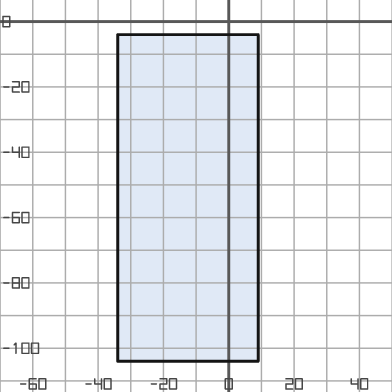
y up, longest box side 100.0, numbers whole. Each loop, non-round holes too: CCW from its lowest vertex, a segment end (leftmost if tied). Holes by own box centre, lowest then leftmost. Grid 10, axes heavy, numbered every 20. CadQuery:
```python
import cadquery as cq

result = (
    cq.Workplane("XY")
    .moveTo(-34.0, -104.0)
    .lineTo(9.0, -104.0)
    .lineTo(9.0, -4.0)
    .lineTo(-34.0, -4.0)
    .close()
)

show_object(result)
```